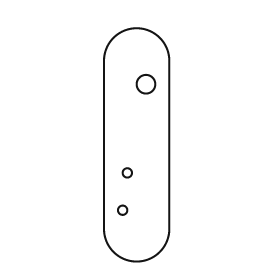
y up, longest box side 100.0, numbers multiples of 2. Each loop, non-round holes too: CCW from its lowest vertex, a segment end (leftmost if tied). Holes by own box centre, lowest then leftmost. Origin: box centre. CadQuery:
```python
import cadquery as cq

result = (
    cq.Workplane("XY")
    .moveTo(-14.0, -36.0)
    .threePointArc((0.0, -50.0), (14.0, -36.0))
    .lineTo(14.0, 36.0)
    .threePointArc((0.0, 50.0), (-14.0, 36.0))
    .close()
    .moveTo(-6.0, -28.0)
    .circle(2.0)
    .moveTo(-4.0, -12.0)
    .circle(2.0)
    .moveTo(4.0, 26.0)
    .circle(4.0)
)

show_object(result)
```